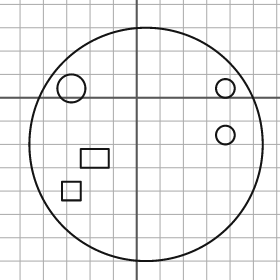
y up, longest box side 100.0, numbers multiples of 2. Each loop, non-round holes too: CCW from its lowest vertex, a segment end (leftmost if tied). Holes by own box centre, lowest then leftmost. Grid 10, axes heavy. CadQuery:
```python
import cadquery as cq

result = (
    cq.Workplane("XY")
    .moveTo(4.0, -20.0)
    .circle(50.0)
    .moveTo(-32.0, -44.0)
    .lineTo(-24.0, -44.0)
    .lineTo(-24.0, -36.0)
    .lineTo(-32.0, -36.0)
    .close()
    .moveTo(-24.0, -30.0)
    .lineTo(-12.0, -30.0)
    .lineTo(-12.0, -22.0)
    .lineTo(-24.0, -22.0)
    .close()
    .moveTo(38.0, -16.0)
    .circle(4.0)
    .moveTo(-28.0, 4.0)
    .circle(6.0)
    .moveTo(38.0, 4.0)
    .circle(4.0)
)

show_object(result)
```